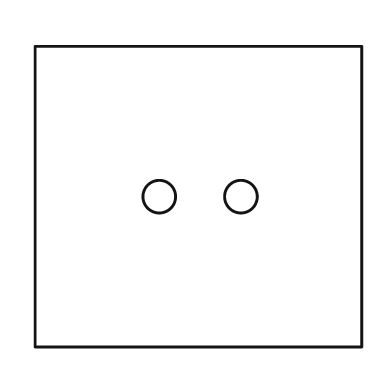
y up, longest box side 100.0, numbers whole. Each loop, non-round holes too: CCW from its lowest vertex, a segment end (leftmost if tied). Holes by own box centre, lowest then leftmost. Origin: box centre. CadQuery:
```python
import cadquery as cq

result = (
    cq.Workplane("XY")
    .moveTo(-50.0, -46.0)
    .lineTo(50.0, -46.0)
    .lineTo(50.0, 46.0)
    .lineTo(-50.0, 46.0)
    .close()
    .moveTo(-12.0, 0.0)
    .circle(5.0)
    .moveTo(13.0, 0.0)
    .circle(5.0)
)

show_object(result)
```